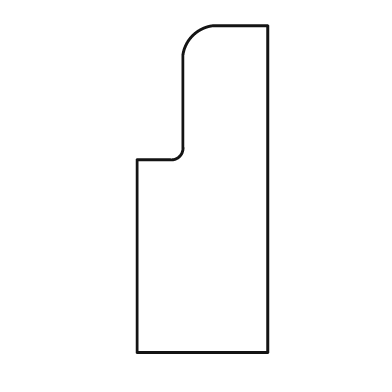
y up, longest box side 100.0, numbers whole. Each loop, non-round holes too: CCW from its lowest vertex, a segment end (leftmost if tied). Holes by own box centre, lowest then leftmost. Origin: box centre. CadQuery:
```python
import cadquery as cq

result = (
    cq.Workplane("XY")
    .moveTo(-20.0, -50.0)
    .lineTo(20.0, -50.0)
    .lineTo(20.0, 50.0)
    .lineTo(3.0, 50.0)
    .threePointArc((-3.0, 47.0), (-6.0, 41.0))
    .lineTo(-6.0, 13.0)
    .threePointArc((-7.0, 10.0), (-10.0, 9.0))
    .lineTo(-20.0, 9.0)
    .close()
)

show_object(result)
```